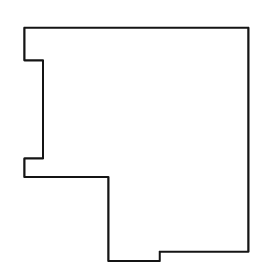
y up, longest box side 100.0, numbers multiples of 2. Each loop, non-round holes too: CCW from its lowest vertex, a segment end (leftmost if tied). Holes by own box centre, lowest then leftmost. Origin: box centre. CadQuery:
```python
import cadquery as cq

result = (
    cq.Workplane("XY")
    .moveTo(-12.0, -50.0)
    .lineTo(10.0, -50.0)
    .lineTo(10.0, -46.0)
    .lineTo(48.0, -46.0)
    .lineTo(48.0, 50.0)
    .lineTo(-48.0, 50.0)
    .lineTo(-48.0, 36.0)
    .lineTo(-40.0, 36.0)
    .lineTo(-40.0, -6.0)
    .lineTo(-48.0, -6.0)
    .lineTo(-48.0, -14.0)
    .lineTo(-12.0, -14.0)
    .close()
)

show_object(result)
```